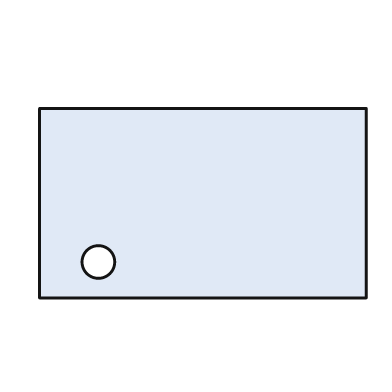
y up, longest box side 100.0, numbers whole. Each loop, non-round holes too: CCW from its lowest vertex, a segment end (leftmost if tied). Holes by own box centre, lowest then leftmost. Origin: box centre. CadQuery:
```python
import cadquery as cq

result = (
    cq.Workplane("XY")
    .moveTo(-50.0, -29.0)
    .lineTo(50.0, -29.0)
    .lineTo(50.0, 29.0)
    .lineTo(-50.0, 29.0)
    .close()
    .moveTo(-32.0, -18.0)
    .circle(5.0)
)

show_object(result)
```